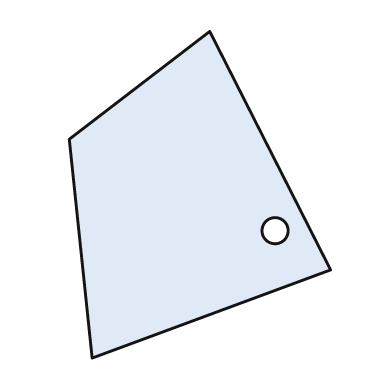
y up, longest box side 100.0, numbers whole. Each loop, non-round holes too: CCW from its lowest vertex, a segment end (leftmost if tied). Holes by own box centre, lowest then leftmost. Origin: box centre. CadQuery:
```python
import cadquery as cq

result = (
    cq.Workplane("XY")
    .moveTo(-33.0, -50.0)
    .lineTo(40.0, -23.0)
    .lineTo(3.0, 50.0)
    .lineTo(-40.0, 17.0)
    .close()
    .moveTo(23.0, -11.0)
    .circle(4.0)
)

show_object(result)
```